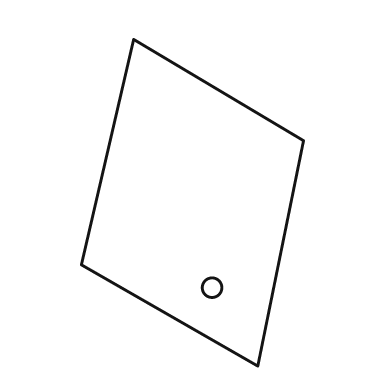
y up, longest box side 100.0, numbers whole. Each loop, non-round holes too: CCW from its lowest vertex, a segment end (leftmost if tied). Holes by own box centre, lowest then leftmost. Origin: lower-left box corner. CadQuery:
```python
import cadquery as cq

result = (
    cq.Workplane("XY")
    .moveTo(54.0, 0.0)
    .lineTo(68.0, 69.0)
    .lineTo(16.0, 100.0)
    .lineTo(0.0, 31.0)
    .close()
    .moveTo(40.0, 24.0)
    .circle(3.0)
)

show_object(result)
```